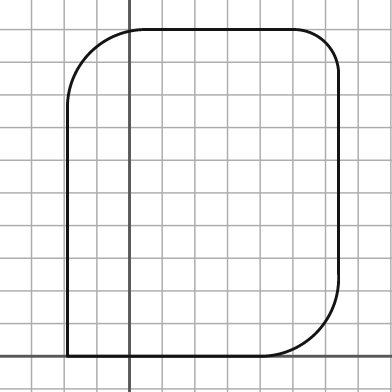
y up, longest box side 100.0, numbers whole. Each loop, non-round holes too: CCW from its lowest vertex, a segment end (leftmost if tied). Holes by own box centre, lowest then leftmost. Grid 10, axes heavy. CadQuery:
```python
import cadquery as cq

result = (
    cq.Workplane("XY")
    .moveTo(-19.0, 0.0)
    .lineTo(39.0, 0.0)
    .threePointArc((57.0, 7.0), (64.0, 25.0))
    .lineTo(64.0, 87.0)
    .threePointArc((60.0, 96.0), (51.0, 100.0))
    .lineTo(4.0, 100.0)
    .threePointArc((-12.0, 93.0), (-19.0, 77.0))
    .close()
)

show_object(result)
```